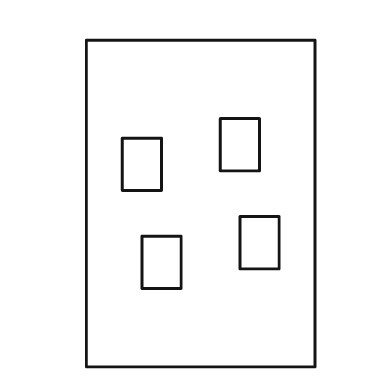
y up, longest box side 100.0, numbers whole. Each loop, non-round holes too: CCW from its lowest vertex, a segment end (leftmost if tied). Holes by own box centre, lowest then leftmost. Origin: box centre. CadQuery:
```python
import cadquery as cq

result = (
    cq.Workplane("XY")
    .moveTo(-35.0, -50.0)
    .lineTo(35.0, -50.0)
    .lineTo(35.0, 50.0)
    .lineTo(-35.0, 50.0)
    .close()
    .moveTo(-18.0, -26.0)
    .lineTo(-6.0, -26.0)
    .lineTo(-6.0, -10.0)
    .lineTo(-18.0, -10.0)
    .close()
    .moveTo(12.0, -20.0)
    .lineTo(24.0, -20.0)
    .lineTo(24.0, -4.0)
    .lineTo(12.0, -4.0)
    .close()
    .moveTo(-24.0, 4.0)
    .lineTo(-12.0, 4.0)
    .lineTo(-12.0, 20.0)
    .lineTo(-24.0, 20.0)
    .close()
    .moveTo(6.0, 10.0)
    .lineTo(18.0, 10.0)
    .lineTo(18.0, 26.0)
    .lineTo(6.0, 26.0)
    .close()
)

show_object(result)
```